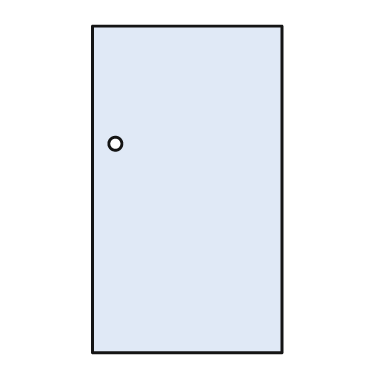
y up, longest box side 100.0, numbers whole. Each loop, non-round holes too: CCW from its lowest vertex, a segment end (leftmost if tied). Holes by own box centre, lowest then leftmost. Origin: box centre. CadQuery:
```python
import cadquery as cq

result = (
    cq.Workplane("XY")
    .moveTo(-29.0, -50.0)
    .lineTo(29.0, -50.0)
    .lineTo(29.0, 50.0)
    .lineTo(-29.0, 50.0)
    .close()
    .moveTo(-22.0, 14.0)
    .circle(2.0)
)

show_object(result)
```